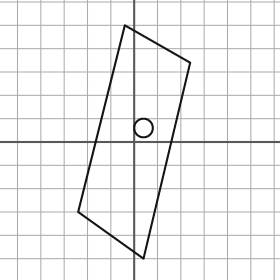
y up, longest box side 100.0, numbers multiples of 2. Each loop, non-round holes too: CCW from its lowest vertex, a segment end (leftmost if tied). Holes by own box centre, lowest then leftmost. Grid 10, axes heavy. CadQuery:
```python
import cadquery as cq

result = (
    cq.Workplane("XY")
    .moveTo(4.0, -50.0)
    .lineTo(24.0, 34.0)
    .lineTo(-4.0, 50.0)
    .lineTo(-24.0, -30.0)
    .close()
    .moveTo(4.0, 6.0)
    .circle(4.0)
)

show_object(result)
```